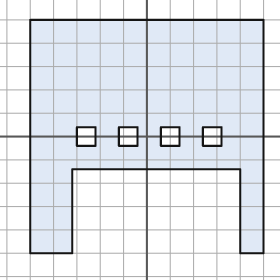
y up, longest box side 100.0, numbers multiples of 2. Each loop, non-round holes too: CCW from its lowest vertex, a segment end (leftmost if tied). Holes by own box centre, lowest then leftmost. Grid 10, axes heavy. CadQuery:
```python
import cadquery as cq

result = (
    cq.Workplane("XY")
    .moveTo(-50.0, -50.0)
    .lineTo(-32.0, -50.0)
    .lineTo(-32.0, -14.0)
    .lineTo(40.0, -14.0)
    .lineTo(40.0, -50.0)
    .lineTo(50.0, -50.0)
    .lineTo(50.0, 50.0)
    .lineTo(-50.0, 50.0)
    .close()
    .moveTo(-30.0, -4.0)
    .lineTo(-22.0, -4.0)
    .lineTo(-22.0, 4.0)
    .lineTo(-30.0, 4.0)
    .close()
    .moveTo(-12.0, -4.0)
    .lineTo(-4.0, -4.0)
    .lineTo(-4.0, 4.0)
    .lineTo(-12.0, 4.0)
    .close()
    .moveTo(6.0, -4.0)
    .lineTo(14.0, -4.0)
    .lineTo(14.0, 4.0)
    .lineTo(6.0, 4.0)
    .close()
    .moveTo(24.0, -4.0)
    .lineTo(32.0, -4.0)
    .lineTo(32.0, 4.0)
    .lineTo(24.0, 4.0)
    .close()
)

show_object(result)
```